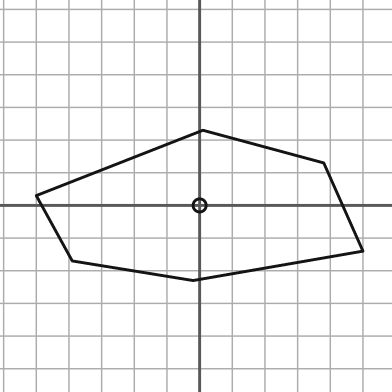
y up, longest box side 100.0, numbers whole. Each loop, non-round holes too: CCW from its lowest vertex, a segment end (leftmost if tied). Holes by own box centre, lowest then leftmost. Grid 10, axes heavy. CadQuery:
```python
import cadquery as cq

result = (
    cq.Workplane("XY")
    .moveTo(-2.0, -23.0)
    .lineTo(50.0, -14.0)
    .lineTo(38.0, 13.0)
    .lineTo(1.0, 23.0)
    .lineTo(-50.0, 3.0)
    .lineTo(-39.0, -17.0)
    .close()
    .moveTo(0.0, 0.0)
    .circle(2.0)
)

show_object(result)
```